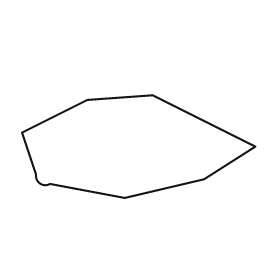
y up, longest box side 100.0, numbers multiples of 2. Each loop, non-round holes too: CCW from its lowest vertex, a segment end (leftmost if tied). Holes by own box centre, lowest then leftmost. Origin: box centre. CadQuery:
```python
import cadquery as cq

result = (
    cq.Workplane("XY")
    .moveTo(-6.0, -22.0)
    .lineTo(28.0, -14.0)
    .lineTo(50.0, 0.0)
    .lineTo(6.0, 22.0)
    .lineTo(-22.0, 20.0)
    .lineTo(-50.0, 6.0)
    .lineTo(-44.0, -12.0)
    .threePointArc((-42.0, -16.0), (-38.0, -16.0))
    .close()
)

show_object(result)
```